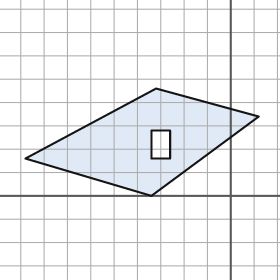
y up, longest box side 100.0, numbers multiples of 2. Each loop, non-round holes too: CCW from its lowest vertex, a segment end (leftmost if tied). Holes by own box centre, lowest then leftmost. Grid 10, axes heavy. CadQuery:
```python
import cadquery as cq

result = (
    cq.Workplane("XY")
    .moveTo(-34.0, 0.0)
    .lineTo(12.0, 34.0)
    .lineTo(-32.0, 46.0)
    .lineTo(-88.0, 16.0)
    .close()
    .moveTo(-34.0, 16.0)
    .lineTo(-26.0, 16.0)
    .lineTo(-26.0, 28.0)
    .lineTo(-34.0, 28.0)
    .close()
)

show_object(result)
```